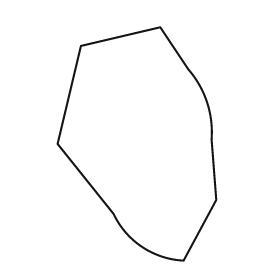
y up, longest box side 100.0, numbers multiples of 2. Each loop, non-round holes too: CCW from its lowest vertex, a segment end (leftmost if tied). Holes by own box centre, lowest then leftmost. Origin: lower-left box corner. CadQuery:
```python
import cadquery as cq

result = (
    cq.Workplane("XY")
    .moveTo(54.0, 0.0)
    .lineTo(68.0, 26.0)
    .lineTo(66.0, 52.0)
    .threePointArc((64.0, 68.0), (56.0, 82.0))
    .lineTo(44.0, 100.0)
    .lineTo(10.0, 92.0)
    .lineTo(0.0, 50.0)
    .lineTo(24.0, 20.0)
    .threePointArc((36.0, 6.0), (54.0, 0.0))
    .close()
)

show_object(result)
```